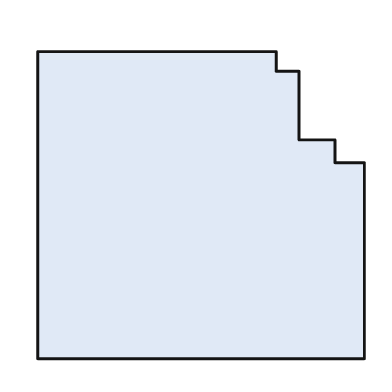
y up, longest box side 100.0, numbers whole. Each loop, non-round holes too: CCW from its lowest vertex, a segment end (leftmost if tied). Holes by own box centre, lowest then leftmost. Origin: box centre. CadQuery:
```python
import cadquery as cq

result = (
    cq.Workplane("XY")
    .moveTo(-50.0, -47.0)
    .lineTo(50.0, -47.0)
    .lineTo(50.0, 13.0)
    .lineTo(41.0, 13.0)
    .lineTo(41.0, 20.0)
    .lineTo(30.0, 20.0)
    .lineTo(30.0, 41.0)
    .lineTo(23.0, 41.0)
    .lineTo(23.0, 47.0)
    .lineTo(-50.0, 47.0)
    .close()
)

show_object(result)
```